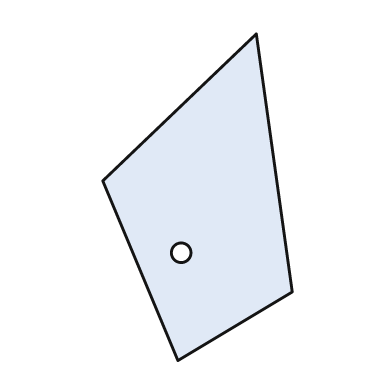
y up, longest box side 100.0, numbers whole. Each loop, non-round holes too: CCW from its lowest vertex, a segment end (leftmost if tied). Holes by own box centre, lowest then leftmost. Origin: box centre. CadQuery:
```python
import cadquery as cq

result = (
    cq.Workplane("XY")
    .moveTo(-6.0, -50.0)
    .lineTo(29.0, -29.0)
    .lineTo(18.0, 50.0)
    .lineTo(-29.0, 5.0)
    .close()
    .moveTo(-5.0, -17.0)
    .circle(3.0)
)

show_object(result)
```